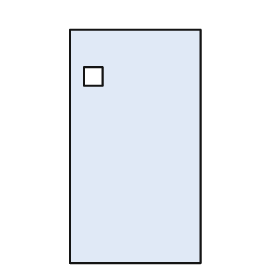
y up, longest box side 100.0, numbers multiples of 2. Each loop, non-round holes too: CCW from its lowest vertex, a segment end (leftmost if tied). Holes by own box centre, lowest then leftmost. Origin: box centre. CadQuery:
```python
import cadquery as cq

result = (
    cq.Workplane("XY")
    .moveTo(-28.0, -50.0)
    .lineTo(28.0, -50.0)
    .lineTo(28.0, 50.0)
    .lineTo(-28.0, 50.0)
    .close()
    .moveTo(-22.0, 26.0)
    .lineTo(-14.0, 26.0)
    .lineTo(-14.0, 34.0)
    .lineTo(-22.0, 34.0)
    .close()
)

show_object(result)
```